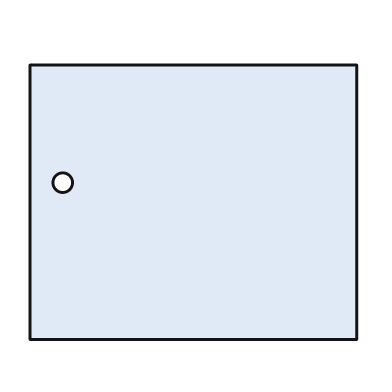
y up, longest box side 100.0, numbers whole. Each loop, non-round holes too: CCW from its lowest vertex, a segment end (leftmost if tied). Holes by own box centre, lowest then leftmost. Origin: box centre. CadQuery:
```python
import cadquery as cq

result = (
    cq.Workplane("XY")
    .moveTo(-50.0, -42.0)
    .lineTo(50.0, -42.0)
    .lineTo(50.0, 42.0)
    .lineTo(-50.0, 42.0)
    .close()
    .moveTo(-40.0, 6.0)
    .circle(3.0)
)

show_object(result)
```